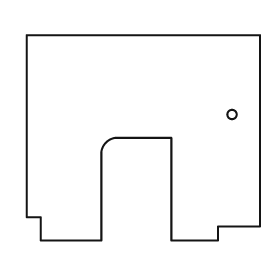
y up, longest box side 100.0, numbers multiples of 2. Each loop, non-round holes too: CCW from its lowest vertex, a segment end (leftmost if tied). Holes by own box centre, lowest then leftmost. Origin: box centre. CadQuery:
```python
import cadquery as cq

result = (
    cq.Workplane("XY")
    .moveTo(-44.0, -44.0)
    .lineTo(-18.0, -44.0)
    .lineTo(-18.0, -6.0)
    .threePointArc((-16.0, -2.0), (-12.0, 0.0))
    .lineTo(12.0, 0.0)
    .lineTo(12.0, -44.0)
    .lineTo(32.0, -44.0)
    .lineTo(32.0, -38.0)
    .lineTo(50.0, -38.0)
    .lineTo(50.0, 44.0)
    .lineTo(-50.0, 44.0)
    .lineTo(-50.0, -34.0)
    .lineTo(-44.0, -34.0)
    .close()
    .moveTo(38.0, 10.0)
    .circle(2.0)
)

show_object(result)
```